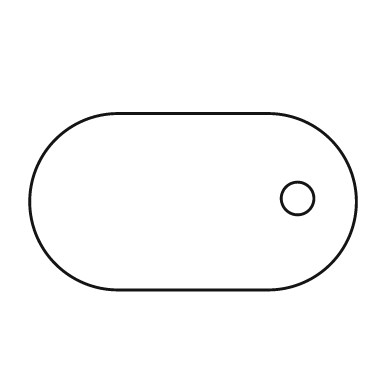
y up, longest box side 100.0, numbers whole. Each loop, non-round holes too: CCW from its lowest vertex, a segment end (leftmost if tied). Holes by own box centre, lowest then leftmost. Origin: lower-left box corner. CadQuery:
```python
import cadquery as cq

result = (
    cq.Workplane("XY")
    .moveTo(27.0, 0.0)
    .lineTo(73.0, 0.0)
    .threePointArc((100.0, 27.0), (73.0, 54.0))
    .lineTo(27.0, 54.0)
    .threePointArc((0.0, 27.0), (27.0, 0.0))
    .close()
    .moveTo(82.0, 28.0)
    .circle(5.0)
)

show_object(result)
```